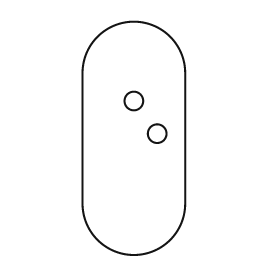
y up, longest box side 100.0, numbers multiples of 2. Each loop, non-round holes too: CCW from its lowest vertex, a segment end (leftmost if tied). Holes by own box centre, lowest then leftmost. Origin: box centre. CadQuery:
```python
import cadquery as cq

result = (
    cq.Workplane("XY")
    .moveTo(-22.0, -28.0)
    .threePointArc((0.0, -50.0), (22.0, -28.0))
    .lineTo(22.0, 28.0)
    .threePointArc((0.0, 50.0), (-22.0, 28.0))
    .close()
    .moveTo(10.0, 2.0)
    .circle(4.0)
    .moveTo(0.0, 16.0)
    .circle(4.0)
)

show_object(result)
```